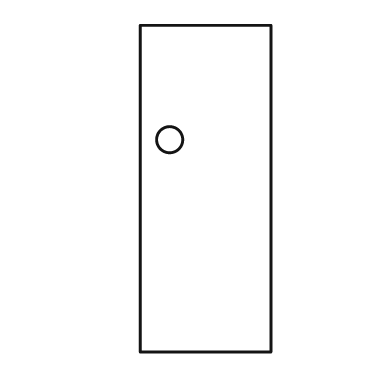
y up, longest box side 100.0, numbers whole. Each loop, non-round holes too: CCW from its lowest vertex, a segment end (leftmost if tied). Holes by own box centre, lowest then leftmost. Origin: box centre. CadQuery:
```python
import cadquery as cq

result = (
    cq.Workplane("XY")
    .moveTo(-20.0, -50.0)
    .lineTo(20.0, -50.0)
    .lineTo(20.0, 50.0)
    .lineTo(-20.0, 50.0)
    .close()
    .moveTo(-11.0, 15.0)
    .circle(4.0)
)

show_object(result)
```